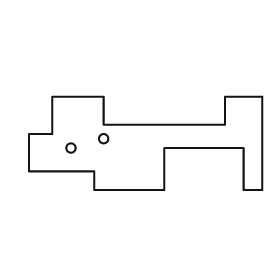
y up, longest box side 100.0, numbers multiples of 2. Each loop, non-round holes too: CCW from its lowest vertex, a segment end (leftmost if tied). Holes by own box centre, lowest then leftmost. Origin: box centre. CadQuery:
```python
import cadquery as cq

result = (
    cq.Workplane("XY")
    .moveTo(-22.0, -20.0)
    .lineTo(8.0, -20.0)
    .lineTo(8.0, -2.0)
    .lineTo(42.0, -2.0)
    .lineTo(42.0, -20.0)
    .lineTo(50.0, -20.0)
    .lineTo(50.0, 20.0)
    .lineTo(34.0, 20.0)
    .lineTo(34.0, 8.0)
    .lineTo(-18.0, 8.0)
    .lineTo(-18.0, 20.0)
    .lineTo(-40.0, 20.0)
    .lineTo(-40.0, 4.0)
    .lineTo(-50.0, 4.0)
    .lineTo(-50.0, -12.0)
    .lineTo(-22.0, -12.0)
    .close()
    .moveTo(-32.0, -2.0)
    .circle(2.0)
    .moveTo(-18.0, 2.0)
    .circle(2.0)
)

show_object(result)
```